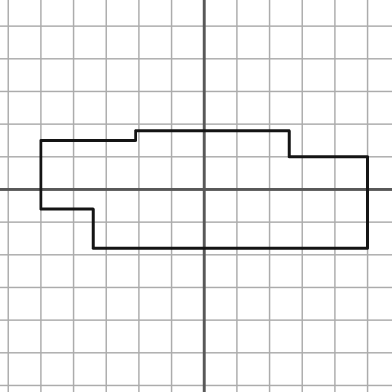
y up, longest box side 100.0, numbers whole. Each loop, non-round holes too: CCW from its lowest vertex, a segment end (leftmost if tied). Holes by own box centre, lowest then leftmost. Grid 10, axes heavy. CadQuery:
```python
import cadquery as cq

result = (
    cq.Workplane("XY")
    .moveTo(-34.0, -18.0)
    .lineTo(50.0, -18.0)
    .lineTo(50.0, 10.0)
    .lineTo(26.0, 10.0)
    .lineTo(26.0, 18.0)
    .lineTo(-21.0, 18.0)
    .lineTo(-21.0, 15.0)
    .lineTo(-50.0, 15.0)
    .lineTo(-50.0, -6.0)
    .lineTo(-34.0, -6.0)
    .close()
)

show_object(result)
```